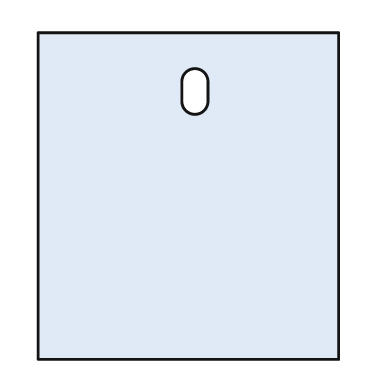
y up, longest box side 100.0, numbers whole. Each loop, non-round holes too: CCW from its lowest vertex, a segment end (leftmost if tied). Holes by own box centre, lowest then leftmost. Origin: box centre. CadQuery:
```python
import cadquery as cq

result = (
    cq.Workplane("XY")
    .moveTo(-46.0, -50.0)
    .lineTo(46.0, -50.0)
    .lineTo(46.0, 50.0)
    .lineTo(-46.0, 50.0)
    .close()
    .moveTo(-2.0, 29.0)
    .threePointArc((2.0, 25.0), (6.0, 29.0))
    .lineTo(6.0, 35.0)
    .threePointArc((2.0, 39.0), (-2.0, 35.0))
    .close()
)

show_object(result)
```